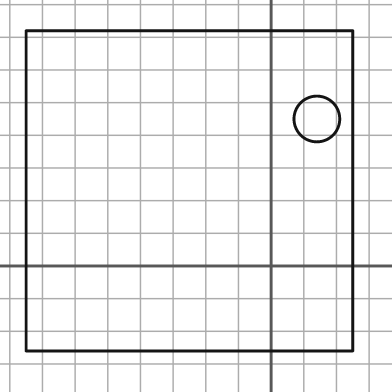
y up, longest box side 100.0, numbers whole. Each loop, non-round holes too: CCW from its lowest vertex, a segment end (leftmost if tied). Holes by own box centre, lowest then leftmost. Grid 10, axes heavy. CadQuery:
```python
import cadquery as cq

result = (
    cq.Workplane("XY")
    .moveTo(-75.0, -26.0)
    .lineTo(25.0, -26.0)
    .lineTo(25.0, 72.0)
    .lineTo(-75.0, 72.0)
    .close()
    .moveTo(14.0, 45.0)
    .circle(7.0)
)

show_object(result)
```